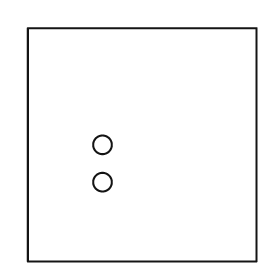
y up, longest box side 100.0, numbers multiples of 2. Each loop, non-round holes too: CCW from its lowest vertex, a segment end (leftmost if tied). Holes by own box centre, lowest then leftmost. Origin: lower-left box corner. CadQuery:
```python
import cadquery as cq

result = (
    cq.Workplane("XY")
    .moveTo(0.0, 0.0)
    .lineTo(98.0, 0.0)
    .lineTo(98.0, 100.0)
    .lineTo(0.0, 100.0)
    .close()
    .moveTo(32.0, 34.0)
    .circle(4.0)
    .moveTo(32.0, 50.0)
    .circle(4.0)
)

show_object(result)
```